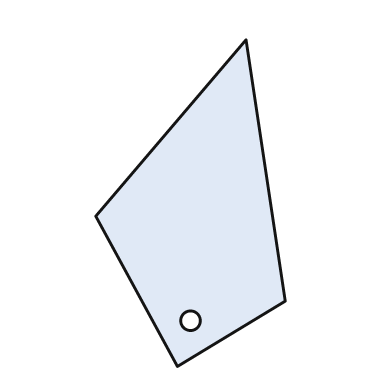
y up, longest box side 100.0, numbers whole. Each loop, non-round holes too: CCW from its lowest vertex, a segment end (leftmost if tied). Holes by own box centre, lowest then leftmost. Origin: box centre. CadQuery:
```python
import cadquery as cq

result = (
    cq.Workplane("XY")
    .moveTo(-4.0, -50.0)
    .lineTo(29.0, -30.0)
    .lineTo(17.0, 50.0)
    .lineTo(-29.0, -4.0)
    .close()
    .moveTo(0.0, -36.0)
    .circle(3.0)
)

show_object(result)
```